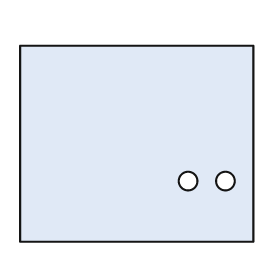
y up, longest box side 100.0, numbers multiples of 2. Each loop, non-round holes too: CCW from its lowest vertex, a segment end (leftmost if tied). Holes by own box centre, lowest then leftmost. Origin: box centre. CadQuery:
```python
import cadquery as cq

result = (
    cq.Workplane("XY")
    .moveTo(-50.0, -42.0)
    .lineTo(50.0, -42.0)
    .lineTo(50.0, 42.0)
    .lineTo(-50.0, 42.0)
    .close()
    .moveTo(22.0, -16.0)
    .circle(4.0)
    .moveTo(38.0, -16.0)
    .circle(4.0)
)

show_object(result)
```